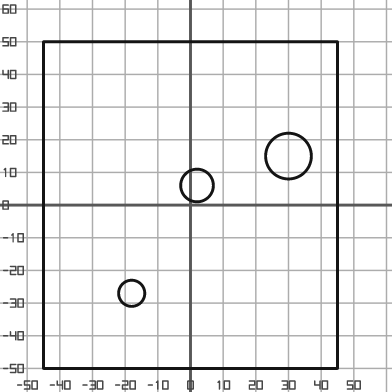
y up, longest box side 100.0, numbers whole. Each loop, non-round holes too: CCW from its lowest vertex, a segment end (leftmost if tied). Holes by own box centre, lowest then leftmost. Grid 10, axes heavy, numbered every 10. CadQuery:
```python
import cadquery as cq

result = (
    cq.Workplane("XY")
    .moveTo(-45.0, -50.0)
    .lineTo(45.0, -50.0)
    .lineTo(45.0, 50.0)
    .lineTo(-45.0, 50.0)
    .close()
    .moveTo(-18.0, -27.0)
    .circle(4.0)
    .moveTo(2.0, 6.0)
    .circle(5.0)
    .moveTo(30.0, 15.0)
    .circle(7.0)
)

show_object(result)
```